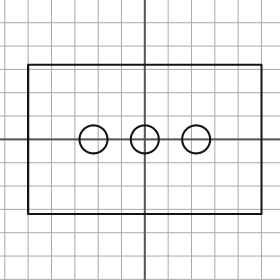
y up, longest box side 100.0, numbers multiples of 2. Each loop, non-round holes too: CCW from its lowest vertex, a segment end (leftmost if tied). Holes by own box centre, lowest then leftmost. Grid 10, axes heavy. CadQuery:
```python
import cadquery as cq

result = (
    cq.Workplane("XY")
    .moveTo(-50.0, -32.0)
    .lineTo(50.0, -32.0)
    .lineTo(50.0, 32.0)
    .lineTo(-50.0, 32.0)
    .close()
    .moveTo(-22.0, 0.0)
    .circle(6.0)
    .moveTo(0.0, 0.0)
    .circle(6.0)
    .moveTo(22.0, 0.0)
    .circle(6.0)
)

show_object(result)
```